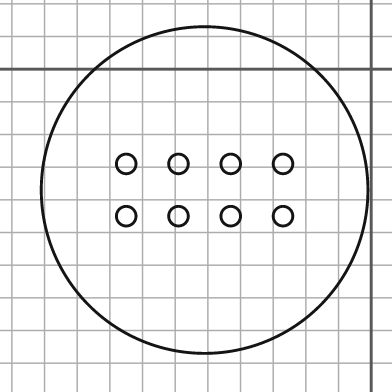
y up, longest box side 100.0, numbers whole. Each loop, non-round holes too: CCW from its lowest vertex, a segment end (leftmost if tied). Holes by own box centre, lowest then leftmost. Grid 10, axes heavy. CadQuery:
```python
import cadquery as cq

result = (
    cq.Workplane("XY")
    .moveTo(-51.0, -37.0)
    .circle(50.0)
    .moveTo(-75.0, -45.0)
    .circle(3.0)
    .moveTo(-59.0, -45.0)
    .circle(3.0)
    .moveTo(-43.0, -45.0)
    .circle(3.0)
    .moveTo(-27.0, -45.0)
    .circle(3.0)
    .moveTo(-75.0, -29.0)
    .circle(3.0)
    .moveTo(-59.0, -29.0)
    .circle(3.0)
    .moveTo(-43.0, -29.0)
    .circle(3.0)
    .moveTo(-27.0, -29.0)
    .circle(3.0)
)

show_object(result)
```